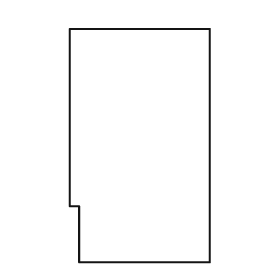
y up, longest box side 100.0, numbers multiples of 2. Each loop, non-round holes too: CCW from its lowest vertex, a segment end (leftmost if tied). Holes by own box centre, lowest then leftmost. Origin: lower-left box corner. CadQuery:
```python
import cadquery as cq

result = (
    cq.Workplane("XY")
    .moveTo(4.0, 0.0)
    .lineTo(60.0, 0.0)
    .lineTo(60.0, 100.0)
    .lineTo(0.0, 100.0)
    .lineTo(0.0, 24.0)
    .lineTo(4.0, 24.0)
    .close()
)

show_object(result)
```